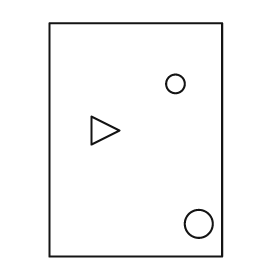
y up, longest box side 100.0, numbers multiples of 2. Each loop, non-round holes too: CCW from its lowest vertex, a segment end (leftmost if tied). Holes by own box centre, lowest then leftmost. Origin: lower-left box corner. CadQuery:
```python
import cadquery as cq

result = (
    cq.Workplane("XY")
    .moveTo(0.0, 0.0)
    .lineTo(74.0, 0.0)
    .lineTo(74.0, 100.0)
    .lineTo(0.0, 100.0)
    .close()
    .moveTo(64.0, 14.0)
    .circle(6.0)
    .moveTo(18.0, 48.0)
    .lineTo(30.0, 54.0)
    .lineTo(18.0, 60.0)
    .close()
    .moveTo(54.0, 74.0)
    .circle(4.0)
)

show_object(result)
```